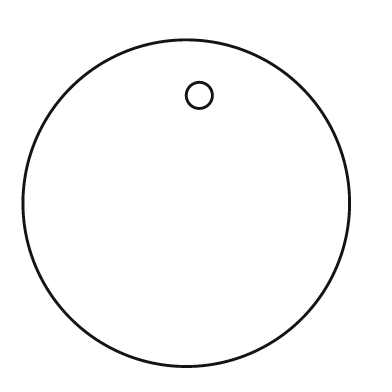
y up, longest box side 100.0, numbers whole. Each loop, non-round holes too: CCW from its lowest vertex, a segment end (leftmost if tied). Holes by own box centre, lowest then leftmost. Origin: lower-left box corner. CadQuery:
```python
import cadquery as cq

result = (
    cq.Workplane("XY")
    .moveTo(50.0, 50.0)
    .circle(50.0)
    .moveTo(54.0, 83.0)
    .circle(4.0)
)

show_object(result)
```